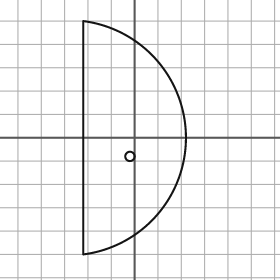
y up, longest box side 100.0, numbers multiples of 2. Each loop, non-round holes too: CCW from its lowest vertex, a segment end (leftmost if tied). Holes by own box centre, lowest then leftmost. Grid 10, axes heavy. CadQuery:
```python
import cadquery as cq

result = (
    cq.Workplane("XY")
    .moveTo(-22.0, -50.0)
    .threePointArc((22.0, 0.0), (-22.0, 50.0))
    .close()
    .moveTo(-2.0, -8.0)
    .circle(2.0)
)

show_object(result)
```